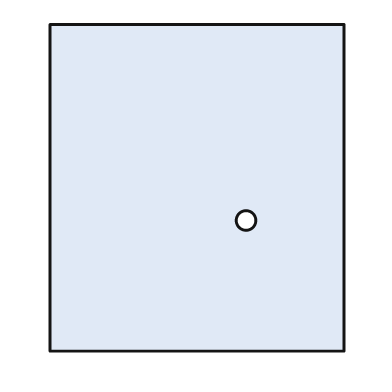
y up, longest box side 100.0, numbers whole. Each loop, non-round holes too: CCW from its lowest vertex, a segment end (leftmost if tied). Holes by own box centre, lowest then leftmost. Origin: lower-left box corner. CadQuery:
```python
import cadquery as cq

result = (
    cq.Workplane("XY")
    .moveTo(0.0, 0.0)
    .lineTo(90.0, 0.0)
    .lineTo(90.0, 100.0)
    .lineTo(0.0, 100.0)
    .close()
    .moveTo(60.0, 40.0)
    .circle(3.0)
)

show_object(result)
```